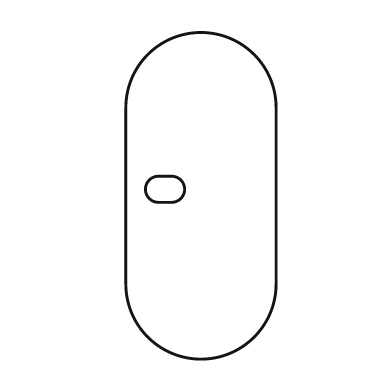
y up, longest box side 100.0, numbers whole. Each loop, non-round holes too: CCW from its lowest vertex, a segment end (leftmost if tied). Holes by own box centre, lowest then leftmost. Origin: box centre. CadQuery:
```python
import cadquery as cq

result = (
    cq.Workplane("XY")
    .moveTo(-23.0, -27.0)
    .threePointArc((0.0, -50.0), (23.0, -27.0))
    .lineTo(23.0, 27.0)
    .threePointArc((0.0, 50.0), (-23.0, 27.0))
    .close()
    .moveTo(-13.0, -2.0)
    .lineTo(-9.0, -2.0)
    .threePointArc((-5.0, 2.0), (-9.0, 6.0))
    .lineTo(-13.0, 6.0)
    .threePointArc((-17.0, 2.0), (-13.0, -2.0))
    .close()
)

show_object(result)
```